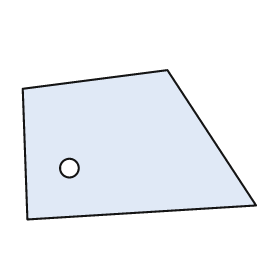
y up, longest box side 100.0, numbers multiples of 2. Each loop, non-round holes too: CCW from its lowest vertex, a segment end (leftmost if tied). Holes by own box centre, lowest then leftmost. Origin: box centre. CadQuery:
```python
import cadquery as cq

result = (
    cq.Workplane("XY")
    .moveTo(-48.0, -32.0)
    .lineTo(50.0, -26.0)
    .lineTo(12.0, 32.0)
    .lineTo(-50.0, 24.0)
    .close()
    .moveTo(-30.0, -10.0)
    .circle(4.0)
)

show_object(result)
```